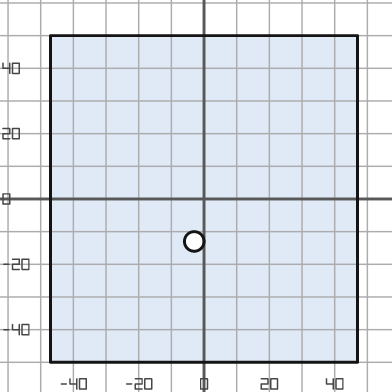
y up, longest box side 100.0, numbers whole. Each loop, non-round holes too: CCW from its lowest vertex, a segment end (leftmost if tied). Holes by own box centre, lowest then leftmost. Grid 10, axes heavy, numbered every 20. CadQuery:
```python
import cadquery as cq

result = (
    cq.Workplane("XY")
    .moveTo(-47.0, -50.0)
    .lineTo(47.0, -50.0)
    .lineTo(47.0, 50.0)
    .lineTo(-47.0, 50.0)
    .close()
    .moveTo(-3.0, -13.0)
    .circle(3.0)
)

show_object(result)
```